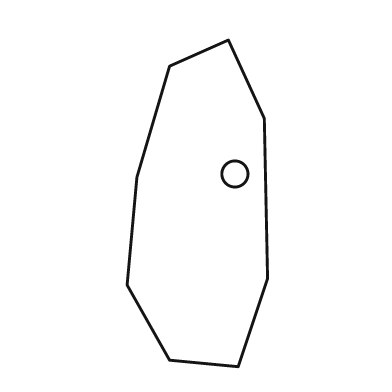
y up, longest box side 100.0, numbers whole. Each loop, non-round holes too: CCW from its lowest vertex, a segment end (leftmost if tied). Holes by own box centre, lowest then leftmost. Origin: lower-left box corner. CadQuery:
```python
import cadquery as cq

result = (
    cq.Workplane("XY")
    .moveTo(34.0, 0.0)
    .lineTo(43.0, 27.0)
    .lineTo(42.0, 76.0)
    .lineTo(31.0, 100.0)
    .lineTo(13.0, 92.0)
    .lineTo(3.0, 58.0)
    .lineTo(0.0, 25.0)
    .lineTo(13.0, 2.0)
    .close()
    .moveTo(33.0, 59.0)
    .circle(4.0)
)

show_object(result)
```